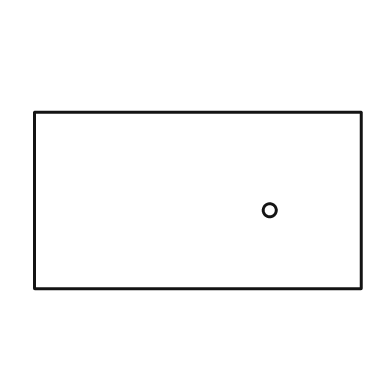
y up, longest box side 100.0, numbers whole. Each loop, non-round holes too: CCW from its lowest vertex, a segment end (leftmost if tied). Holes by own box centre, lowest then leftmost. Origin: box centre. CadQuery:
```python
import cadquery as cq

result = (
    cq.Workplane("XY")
    .moveTo(-50.0, -27.0)
    .lineTo(50.0, -27.0)
    .lineTo(50.0, 27.0)
    .lineTo(-50.0, 27.0)
    .close()
    .moveTo(22.0, -3.0)
    .circle(2.0)
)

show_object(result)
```